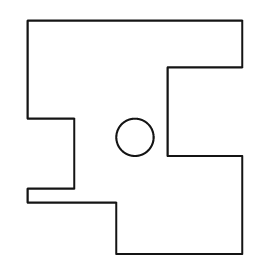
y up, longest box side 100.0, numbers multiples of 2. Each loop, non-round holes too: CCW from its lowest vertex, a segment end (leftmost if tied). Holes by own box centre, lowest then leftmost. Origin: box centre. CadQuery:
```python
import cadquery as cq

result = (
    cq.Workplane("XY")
    .moveTo(-8.0, -50.0)
    .lineTo(46.0, -50.0)
    .lineTo(46.0, -8.0)
    .lineTo(14.0, -8.0)
    .lineTo(14.0, 30.0)
    .lineTo(46.0, 30.0)
    .lineTo(46.0, 50.0)
    .lineTo(-46.0, 50.0)
    .lineTo(-46.0, 8.0)
    .lineTo(-26.0, 8.0)
    .lineTo(-26.0, -22.0)
    .lineTo(-46.0, -22.0)
    .lineTo(-46.0, -28.0)
    .lineTo(-8.0, -28.0)
    .close()
    .moveTo(0.0, 0.0)
    .circle(8.0)
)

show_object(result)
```